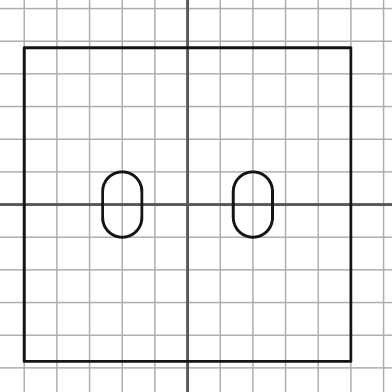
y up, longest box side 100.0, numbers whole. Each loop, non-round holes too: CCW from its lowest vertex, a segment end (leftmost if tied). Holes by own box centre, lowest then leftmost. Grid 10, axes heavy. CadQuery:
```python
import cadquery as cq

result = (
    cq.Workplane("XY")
    .moveTo(-50.0, -48.0)
    .lineTo(50.0, -48.0)
    .lineTo(50.0, 48.0)
    .lineTo(-50.0, 48.0)
    .close()
    .moveTo(-26.0, -4.0)
    .threePointArc((-20.0, -10.0), (-14.0, -4.0))
    .lineTo(-14.0, 4.0)
    .threePointArc((-20.0, 10.0), (-26.0, 4.0))
    .close()
    .moveTo(14.0, -4.0)
    .threePointArc((20.0, -10.0), (26.0, -4.0))
    .lineTo(26.0, 4.0)
    .threePointArc((20.0, 10.0), (14.0, 4.0))
    .close()
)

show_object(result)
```